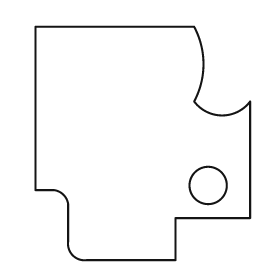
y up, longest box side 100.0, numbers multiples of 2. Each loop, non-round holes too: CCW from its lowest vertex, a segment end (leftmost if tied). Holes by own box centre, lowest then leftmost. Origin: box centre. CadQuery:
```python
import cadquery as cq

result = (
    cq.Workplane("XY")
    .moveTo(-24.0, -50.0)
    .lineTo(14.0, -50.0)
    .lineTo(14.0, -32.0)
    .lineTo(46.0, -32.0)
    .lineTo(46.0, 18.0)
    .threePointArc((34.0, 12.0), (22.0, 18.0))
    .threePointArc((26.0, 34.0), (22.0, 50.0))
    .lineTo(-46.0, 50.0)
    .lineTo(-46.0, -20.0)
    .lineTo(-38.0, -20.0)
    .threePointArc((-34.0, -22.0), (-32.0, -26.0))
    .lineTo(-32.0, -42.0)
    .threePointArc((-30.0, -48.0), (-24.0, -50.0))
    .close()
    .moveTo(28.0, -18.0)
    .circle(8.0)
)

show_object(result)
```